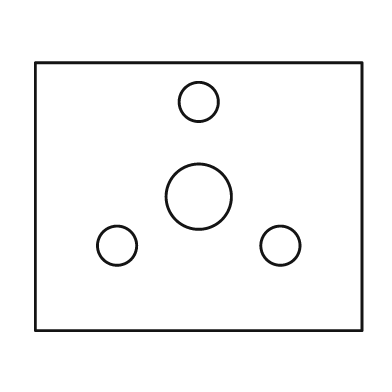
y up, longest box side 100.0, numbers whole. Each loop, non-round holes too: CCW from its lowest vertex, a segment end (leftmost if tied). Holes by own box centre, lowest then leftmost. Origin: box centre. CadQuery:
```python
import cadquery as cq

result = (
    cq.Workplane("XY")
    .moveTo(-50.0, -41.0)
    .lineTo(50.0, -41.0)
    .lineTo(50.0, 41.0)
    .lineTo(-50.0, 41.0)
    .close()
    .moveTo(-25.0, -15.0)
    .circle(6.0)
    .moveTo(25.0, -15.0)
    .circle(6.0)
    .moveTo(0.0, 0.0)
    .circle(10.0)
    .moveTo(0.0, 29.0)
    .circle(6.0)
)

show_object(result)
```